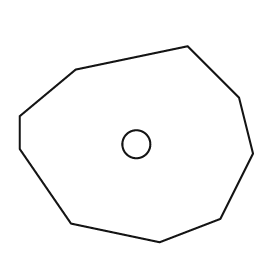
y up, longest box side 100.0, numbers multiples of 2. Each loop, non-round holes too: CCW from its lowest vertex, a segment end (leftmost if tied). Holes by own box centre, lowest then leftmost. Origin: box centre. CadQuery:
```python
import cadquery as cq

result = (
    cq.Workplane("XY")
    .moveTo(10.0, -42.0)
    .lineTo(36.0, -32.0)
    .lineTo(50.0, -4.0)
    .lineTo(44.0, 20.0)
    .lineTo(22.0, 42.0)
    .lineTo(-26.0, 32.0)
    .lineTo(-50.0, 12.0)
    .lineTo(-50.0, -2.0)
    .lineTo(-28.0, -34.0)
    .close()
    .moveTo(0.0, 0.0)
    .circle(6.0)
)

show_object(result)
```